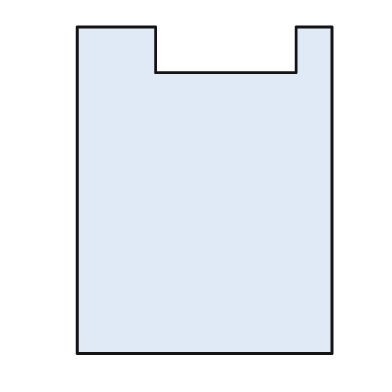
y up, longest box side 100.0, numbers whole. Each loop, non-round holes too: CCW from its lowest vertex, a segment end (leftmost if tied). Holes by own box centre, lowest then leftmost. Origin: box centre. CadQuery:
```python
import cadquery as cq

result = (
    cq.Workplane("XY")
    .moveTo(-39.0, -50.0)
    .lineTo(39.0, -50.0)
    .lineTo(39.0, 50.0)
    .lineTo(28.0, 50.0)
    .lineTo(28.0, 36.0)
    .lineTo(-15.0, 36.0)
    .lineTo(-15.0, 50.0)
    .lineTo(-39.0, 50.0)
    .close()
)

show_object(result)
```